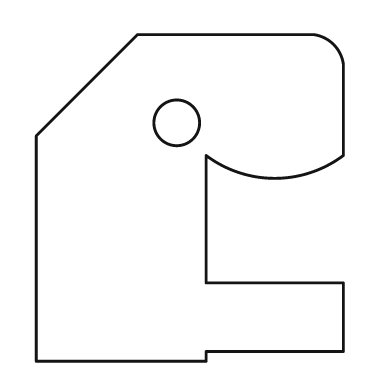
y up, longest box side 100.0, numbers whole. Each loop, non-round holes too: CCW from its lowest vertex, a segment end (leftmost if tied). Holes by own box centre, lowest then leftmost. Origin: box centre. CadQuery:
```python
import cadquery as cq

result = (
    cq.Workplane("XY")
    .moveTo(-47.0, -50.0)
    .lineTo(5.0, -50.0)
    .lineTo(5.0, -47.0)
    .lineTo(47.0, -47.0)
    .lineTo(47.0, -26.0)
    .lineTo(5.0, -26.0)
    .lineTo(5.0, 13.0)
    .threePointArc((26.0, 6.0), (47.0, 13.0))
    .lineTo(47.0, 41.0)
    .threePointArc((44.0, 47.0), (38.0, 50.0))
    .lineTo(-16.0, 50.0)
    .lineTo(-47.0, 19.0)
    .close()
    .moveTo(-4.0, 23.0)
    .circle(7.0)
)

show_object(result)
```